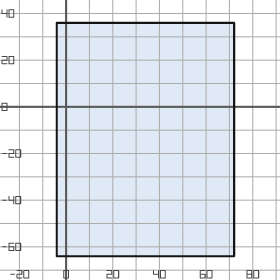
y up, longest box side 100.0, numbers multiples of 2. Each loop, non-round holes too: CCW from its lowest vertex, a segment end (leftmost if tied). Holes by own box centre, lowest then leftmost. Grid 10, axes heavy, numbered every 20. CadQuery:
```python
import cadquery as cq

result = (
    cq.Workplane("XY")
    .moveTo(-4.0, -64.0)
    .lineTo(72.0, -64.0)
    .lineTo(72.0, 36.0)
    .lineTo(-4.0, 36.0)
    .close()
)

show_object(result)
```